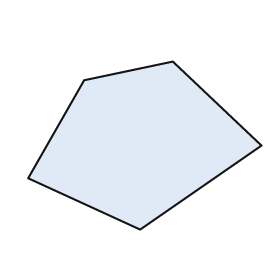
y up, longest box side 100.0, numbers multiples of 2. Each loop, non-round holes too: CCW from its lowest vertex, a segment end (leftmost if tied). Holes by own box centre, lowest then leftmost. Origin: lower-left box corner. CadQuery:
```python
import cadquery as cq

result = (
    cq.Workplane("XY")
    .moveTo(48.0, 0.0)
    .lineTo(100.0, 36.0)
    .lineTo(62.0, 72.0)
    .lineTo(24.0, 64.0)
    .lineTo(0.0, 22.0)
    .close()
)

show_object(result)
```